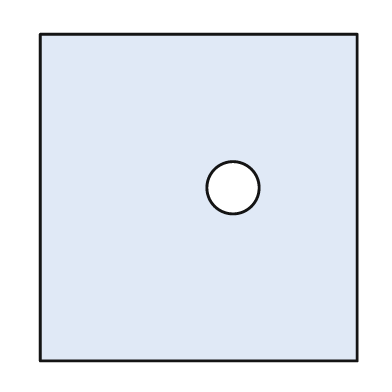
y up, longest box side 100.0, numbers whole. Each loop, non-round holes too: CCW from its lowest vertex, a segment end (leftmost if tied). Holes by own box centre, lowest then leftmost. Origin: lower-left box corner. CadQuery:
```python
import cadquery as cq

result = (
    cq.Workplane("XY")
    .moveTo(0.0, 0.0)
    .lineTo(97.0, 0.0)
    .lineTo(97.0, 100.0)
    .lineTo(0.0, 100.0)
    .close()
    .moveTo(59.0, 53.0)
    .circle(8.0)
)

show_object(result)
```